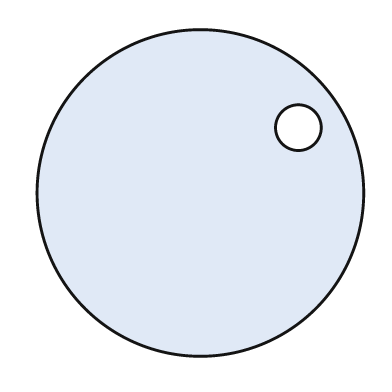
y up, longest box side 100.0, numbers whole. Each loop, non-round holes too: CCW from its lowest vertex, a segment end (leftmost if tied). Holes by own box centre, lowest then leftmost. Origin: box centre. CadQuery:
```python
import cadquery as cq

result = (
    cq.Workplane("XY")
    .moveTo(0.0, 0.0)
    .circle(50.0)
    .moveTo(30.0, 20.0)
    .circle(7.0)
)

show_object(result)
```